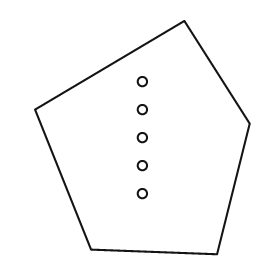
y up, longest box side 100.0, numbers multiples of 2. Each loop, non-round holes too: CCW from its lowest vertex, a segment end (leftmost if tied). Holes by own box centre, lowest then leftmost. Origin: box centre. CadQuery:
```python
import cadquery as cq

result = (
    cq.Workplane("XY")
    .moveTo(32.0, -50.0)
    .lineTo(46.0, 6.0)
    .lineTo(18.0, 50.0)
    .lineTo(-46.0, 12.0)
    .lineTo(-22.0, -48.0)
    .close()
    .moveTo(0.0, -24.0)
    .circle(2.0)
    .moveTo(0.0, -12.0)
    .circle(2.0)
    .moveTo(0.0, 0.0)
    .circle(2.0)
    .moveTo(0.0, 12.0)
    .circle(2.0)
    .moveTo(0.0, 24.0)
    .circle(2.0)
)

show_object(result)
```